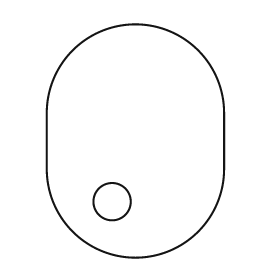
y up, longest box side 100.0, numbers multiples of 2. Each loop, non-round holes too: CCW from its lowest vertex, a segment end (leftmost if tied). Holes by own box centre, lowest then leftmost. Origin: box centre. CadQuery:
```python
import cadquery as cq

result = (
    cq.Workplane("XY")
    .moveTo(-38.0, -12.0)
    .threePointArc((0.0, -50.0), (38.0, -12.0))
    .lineTo(38.0, 12.0)
    .threePointArc((0.0, 50.0), (-38.0, 12.0))
    .close()
    .moveTo(-10.0, -26.0)
    .circle(8.0)
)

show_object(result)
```